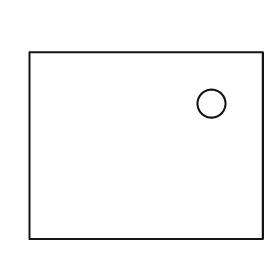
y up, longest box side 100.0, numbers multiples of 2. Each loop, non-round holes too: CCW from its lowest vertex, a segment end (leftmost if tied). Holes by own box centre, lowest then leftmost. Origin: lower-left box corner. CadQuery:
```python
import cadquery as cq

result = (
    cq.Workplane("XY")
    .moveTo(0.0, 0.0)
    .lineTo(100.0, 0.0)
    .lineTo(100.0, 80.0)
    .lineTo(0.0, 80.0)
    .close()
    .moveTo(78.0, 58.0)
    .circle(6.0)
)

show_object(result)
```